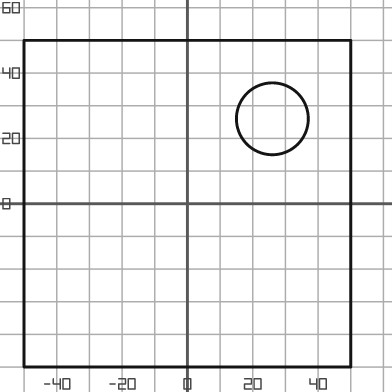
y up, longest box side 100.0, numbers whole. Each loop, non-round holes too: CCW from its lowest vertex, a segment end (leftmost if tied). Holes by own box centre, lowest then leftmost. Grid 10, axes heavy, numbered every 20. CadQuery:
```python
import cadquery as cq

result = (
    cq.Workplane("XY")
    .moveTo(-50.0, -50.0)
    .lineTo(50.0, -50.0)
    .lineTo(50.0, 50.0)
    .lineTo(-50.0, 50.0)
    .close()
    .moveTo(26.0, 26.0)
    .circle(11.0)
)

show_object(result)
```